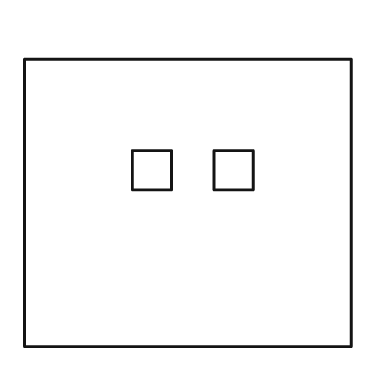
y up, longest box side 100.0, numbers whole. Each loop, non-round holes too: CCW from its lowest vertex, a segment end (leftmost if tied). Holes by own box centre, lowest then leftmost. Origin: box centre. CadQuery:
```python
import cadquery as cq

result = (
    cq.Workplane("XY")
    .moveTo(-50.0, -44.0)
    .lineTo(50.0, -44.0)
    .lineTo(50.0, 44.0)
    .lineTo(-50.0, 44.0)
    .close()
    .moveTo(-17.0, 4.0)
    .lineTo(-5.0, 4.0)
    .lineTo(-5.0, 16.0)
    .lineTo(-17.0, 16.0)
    .close()
    .moveTo(8.0, 4.0)
    .lineTo(20.0, 4.0)
    .lineTo(20.0, 16.0)
    .lineTo(8.0, 16.0)
    .close()
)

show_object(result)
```